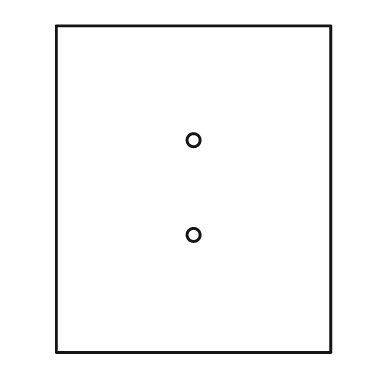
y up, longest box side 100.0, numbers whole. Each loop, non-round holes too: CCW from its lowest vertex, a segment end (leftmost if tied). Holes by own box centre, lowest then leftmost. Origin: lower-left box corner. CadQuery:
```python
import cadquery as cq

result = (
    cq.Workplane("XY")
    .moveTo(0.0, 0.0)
    .lineTo(84.0, 0.0)
    .lineTo(84.0, 100.0)
    .lineTo(0.0, 100.0)
    .close()
    .moveTo(42.0, 36.0)
    .circle(2.0)
    .moveTo(42.0, 65.0)
    .circle(2.0)
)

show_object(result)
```